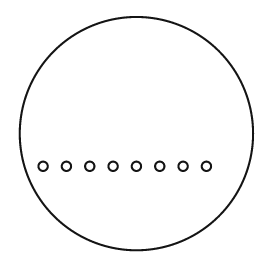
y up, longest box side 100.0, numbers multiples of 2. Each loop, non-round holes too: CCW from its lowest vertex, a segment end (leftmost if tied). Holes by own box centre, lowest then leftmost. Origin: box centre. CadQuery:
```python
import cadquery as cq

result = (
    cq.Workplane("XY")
    .moveTo(0.0, 0.0)
    .circle(50.0)
    .moveTo(-40.0, -14.0)
    .circle(2.0)
    .moveTo(-30.0, -14.0)
    .circle(2.0)
    .moveTo(-20.0, -14.0)
    .circle(2.0)
    .moveTo(-10.0, -14.0)
    .circle(2.0)
    .moveTo(0.0, -14.0)
    .circle(2.0)
    .moveTo(10.0, -14.0)
    .circle(2.0)
    .moveTo(20.0, -14.0)
    .circle(2.0)
    .moveTo(30.0, -14.0)
    .circle(2.0)
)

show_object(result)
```